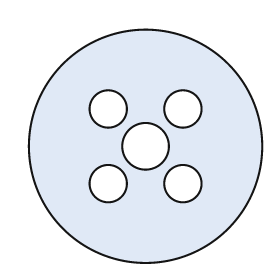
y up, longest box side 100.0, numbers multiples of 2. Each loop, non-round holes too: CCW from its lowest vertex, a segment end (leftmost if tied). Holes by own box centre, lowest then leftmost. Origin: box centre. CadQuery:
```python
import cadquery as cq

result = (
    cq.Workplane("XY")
    .moveTo(0.0, 0.0)
    .circle(50.0)
    .moveTo(-16.0, -16.0)
    .circle(8.0)
    .moveTo(16.0, -16.0)
    .circle(8.0)
    .moveTo(0.0, 0.0)
    .circle(10.0)
    .moveTo(-16.0, 16.0)
    .circle(8.0)
    .moveTo(16.0, 16.0)
    .circle(8.0)
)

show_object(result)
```